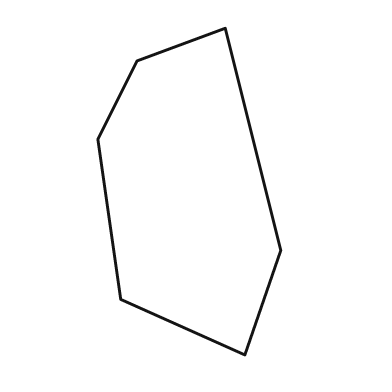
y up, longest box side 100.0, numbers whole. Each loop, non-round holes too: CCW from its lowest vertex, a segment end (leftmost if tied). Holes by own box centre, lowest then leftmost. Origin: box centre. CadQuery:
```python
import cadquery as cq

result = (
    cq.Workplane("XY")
    .moveTo(17.0, -50.0)
    .lineTo(28.0, -18.0)
    .lineTo(11.0, 50.0)
    .lineTo(-16.0, 40.0)
    .lineTo(-28.0, 16.0)
    .lineTo(-21.0, -33.0)
    .close()
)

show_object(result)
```